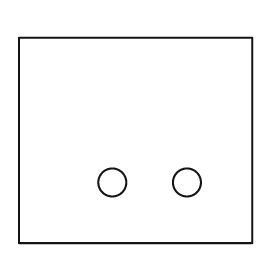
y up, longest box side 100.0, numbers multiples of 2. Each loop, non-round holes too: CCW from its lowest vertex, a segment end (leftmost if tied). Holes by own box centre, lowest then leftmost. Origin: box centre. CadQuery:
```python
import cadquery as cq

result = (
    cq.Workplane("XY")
    .moveTo(-50.0, -44.0)
    .lineTo(50.0, -44.0)
    .lineTo(50.0, 44.0)
    .lineTo(-50.0, 44.0)
    .close()
    .moveTo(-10.0, -18.0)
    .circle(6.0)
    .moveTo(22.0, -18.0)
    .circle(6.0)
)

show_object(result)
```